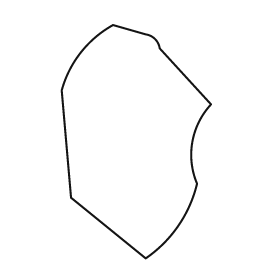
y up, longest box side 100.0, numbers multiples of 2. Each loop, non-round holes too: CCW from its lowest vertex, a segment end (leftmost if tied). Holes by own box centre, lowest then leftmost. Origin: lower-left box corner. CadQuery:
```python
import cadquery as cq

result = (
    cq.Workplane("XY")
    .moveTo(36.0, 0.0)
    .threePointArc((50.0, 14.0), (58.0, 32.0))
    .threePointArc((56.0, 50.0), (64.0, 66.0))
    .lineTo(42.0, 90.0)
    .threePointArc((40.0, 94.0), (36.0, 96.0))
    .lineTo(22.0, 100.0)
    .threePointArc((8.0, 88.0), (0.0, 72.0))
    .lineTo(4.0, 26.0)
    .close()
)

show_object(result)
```